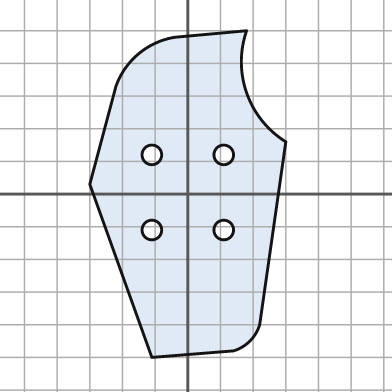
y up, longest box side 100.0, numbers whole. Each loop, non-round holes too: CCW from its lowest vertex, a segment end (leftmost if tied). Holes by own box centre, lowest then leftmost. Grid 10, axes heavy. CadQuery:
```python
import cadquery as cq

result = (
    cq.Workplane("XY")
    .moveTo(-11.0, -50.0)
    .lineTo(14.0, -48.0)
    .threePointArc((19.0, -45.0), (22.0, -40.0))
    .lineTo(30.0, 16.0)
    .threePointArc((18.0, 31.0), (18.0, 50.0))
    .lineTo(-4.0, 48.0)
    .threePointArc((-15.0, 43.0), (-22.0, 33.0))
    .lineTo(-30.0, 3.0)
    .close()
    .moveTo(-11.0, -11.0)
    .circle(3.0)
    .moveTo(11.0, -11.0)
    .circle(3.0)
    .moveTo(-11.0, 12.0)
    .circle(3.0)
    .moveTo(11.0, 12.0)
    .circle(3.0)
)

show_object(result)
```